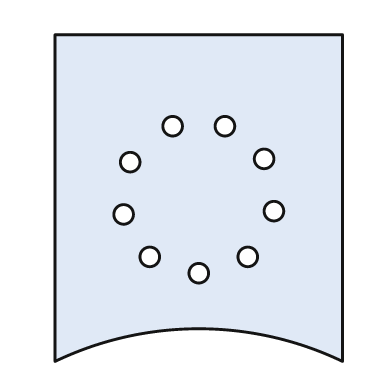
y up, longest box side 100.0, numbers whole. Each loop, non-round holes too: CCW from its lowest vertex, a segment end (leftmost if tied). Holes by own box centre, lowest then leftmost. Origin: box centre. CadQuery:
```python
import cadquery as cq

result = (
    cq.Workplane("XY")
    .moveTo(-44.0, -50.0)
    .threePointArc((0.0, -40.0), (44.0, -50.0))
    .lineTo(44.0, 50.0)
    .lineTo(-44.0, 50.0)
    .close()
    .moveTo(0.0, -23.0)
    .circle(3.0)
    .moveTo(-15.0, -18.0)
    .circle(3.0)
    .moveTo(15.0, -18.0)
    .circle(3.0)
    .moveTo(-23.0, -5.0)
    .circle(3.0)
    .moveTo(23.0, -4.0)
    .circle(3.0)
    .moveTo(-21.0, 11.0)
    .circle(3.0)
    .moveTo(20.0, 12.0)
    .circle(3.0)
    .moveTo(-8.0, 22.0)
    .circle(3.0)
    .moveTo(8.0, 22.0)
    .circle(3.0)
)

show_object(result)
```